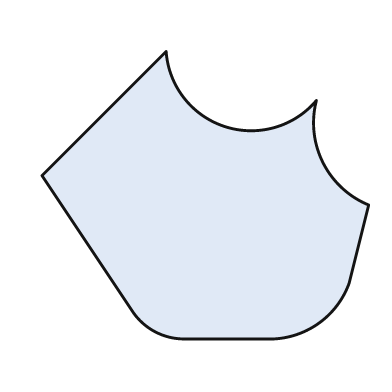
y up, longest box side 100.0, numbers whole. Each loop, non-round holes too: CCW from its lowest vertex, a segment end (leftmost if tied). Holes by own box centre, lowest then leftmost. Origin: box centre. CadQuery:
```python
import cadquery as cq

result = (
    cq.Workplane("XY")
    .moveTo(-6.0, -44.0)
    .lineTo(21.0, -44.0)
    .threePointArc((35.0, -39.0), (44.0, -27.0))
    .lineTo(50.0, -3.0)
    .threePointArc((36.0, 10.0), (34.0, 29.0))
    .threePointArc((6.0, 21.0), (-12.0, 44.0))
    .lineTo(-50.0, 6.0)
    .lineTo(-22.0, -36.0)
    .threePointArc((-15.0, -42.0), (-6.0, -44.0))
    .close()
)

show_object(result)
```